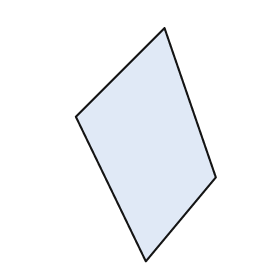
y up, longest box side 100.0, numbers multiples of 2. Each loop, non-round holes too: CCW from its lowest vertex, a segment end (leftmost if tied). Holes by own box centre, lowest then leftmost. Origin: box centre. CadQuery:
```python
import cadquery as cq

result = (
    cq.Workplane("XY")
    .moveTo(0.0, -50.0)
    .lineTo(30.0, -14.0)
    .lineTo(8.0, 50.0)
    .lineTo(-30.0, 12.0)
    .close()
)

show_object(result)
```